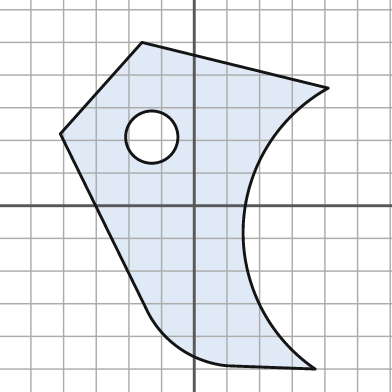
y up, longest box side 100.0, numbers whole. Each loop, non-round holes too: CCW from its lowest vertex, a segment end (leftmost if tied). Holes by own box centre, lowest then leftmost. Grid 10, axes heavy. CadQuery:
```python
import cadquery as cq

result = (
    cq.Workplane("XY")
    .moveTo(37.0, -50.0)
    .threePointArc((15.0, -6.0), (41.0, 36.0))
    .lineTo(-16.0, 50.0)
    .lineTo(-41.0, 22.0)
    .lineTo(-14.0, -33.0)
    .threePointArc((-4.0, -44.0), (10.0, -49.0))
    .close()
    .moveTo(-13.0, 21.0)
    .circle(8.0)
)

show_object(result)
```